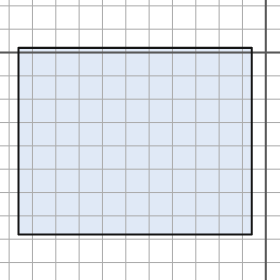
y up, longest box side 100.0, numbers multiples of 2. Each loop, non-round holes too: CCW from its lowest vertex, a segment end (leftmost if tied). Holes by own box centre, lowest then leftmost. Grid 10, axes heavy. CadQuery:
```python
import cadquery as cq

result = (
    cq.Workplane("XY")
    .moveTo(-106.0, -78.0)
    .lineTo(-6.0, -78.0)
    .lineTo(-6.0, 2.0)
    .lineTo(-106.0, 2.0)
    .close()
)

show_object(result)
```